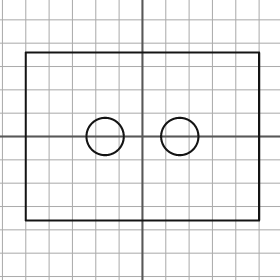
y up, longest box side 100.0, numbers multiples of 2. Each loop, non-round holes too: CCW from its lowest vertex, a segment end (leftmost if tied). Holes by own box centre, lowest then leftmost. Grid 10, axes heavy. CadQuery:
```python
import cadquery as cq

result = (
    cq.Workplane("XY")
    .moveTo(-50.0, -36.0)
    .lineTo(50.0, -36.0)
    .lineTo(50.0, 36.0)
    .lineTo(-50.0, 36.0)
    .close()
    .moveTo(-16.0, 0.0)
    .circle(8.0)
    .moveTo(16.0, 0.0)
    .circle(8.0)
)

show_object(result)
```